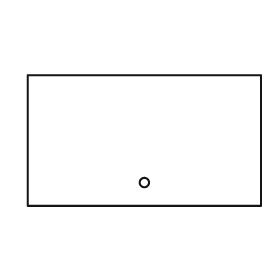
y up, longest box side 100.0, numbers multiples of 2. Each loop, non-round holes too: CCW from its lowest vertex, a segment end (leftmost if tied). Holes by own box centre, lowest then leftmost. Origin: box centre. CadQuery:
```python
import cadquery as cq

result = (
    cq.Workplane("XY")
    .moveTo(-50.0, -28.0)
    .lineTo(50.0, -28.0)
    .lineTo(50.0, 28.0)
    .lineTo(-50.0, 28.0)
    .close()
    .moveTo(0.0, -18.0)
    .circle(2.0)
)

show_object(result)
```